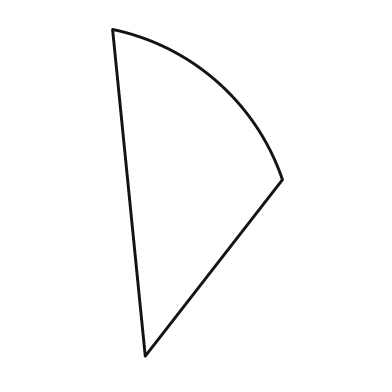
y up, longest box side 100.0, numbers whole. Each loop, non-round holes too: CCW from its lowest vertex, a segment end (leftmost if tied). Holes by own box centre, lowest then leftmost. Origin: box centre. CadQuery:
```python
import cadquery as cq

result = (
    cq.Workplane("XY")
    .moveTo(-16.0, -50.0)
    .lineTo(26.0, 4.0)
    .threePointArc((6.0, 34.0), (-26.0, 50.0))
    .close()
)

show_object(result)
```